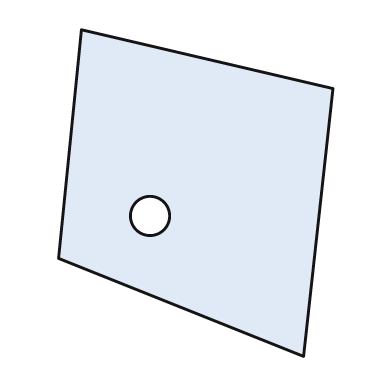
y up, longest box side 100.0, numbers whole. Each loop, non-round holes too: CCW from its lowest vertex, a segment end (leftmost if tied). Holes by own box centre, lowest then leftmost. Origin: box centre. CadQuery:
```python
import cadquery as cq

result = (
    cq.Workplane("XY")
    .moveTo(33.0, -50.0)
    .lineTo(42.0, 32.0)
    .lineTo(-35.0, 50.0)
    .lineTo(-42.0, -20.0)
    .close()
    .moveTo(-14.0, -7.0)
    .circle(6.0)
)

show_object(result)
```